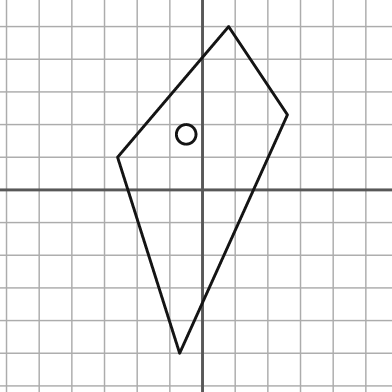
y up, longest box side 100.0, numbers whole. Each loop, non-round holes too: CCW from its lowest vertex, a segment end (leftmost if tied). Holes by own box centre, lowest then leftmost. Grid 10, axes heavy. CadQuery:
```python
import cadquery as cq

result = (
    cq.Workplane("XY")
    .moveTo(-7.0, -50.0)
    .lineTo(26.0, 23.0)
    .lineTo(8.0, 50.0)
    .lineTo(-26.0, 10.0)
    .close()
    .moveTo(-5.0, 17.0)
    .circle(3.0)
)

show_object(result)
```